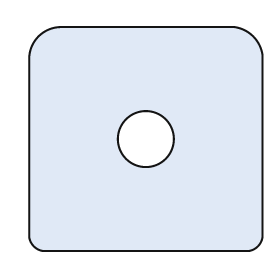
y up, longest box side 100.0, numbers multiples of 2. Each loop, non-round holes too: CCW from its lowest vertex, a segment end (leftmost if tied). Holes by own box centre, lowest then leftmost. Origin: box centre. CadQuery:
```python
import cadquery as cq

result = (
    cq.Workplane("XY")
    .moveTo(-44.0, -48.0)
    .lineTo(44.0, -48.0)
    .threePointArc((48.0, -46.0), (50.0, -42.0))
    .lineTo(50.0, 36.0)
    .threePointArc((46.0, 44.0), (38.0, 48.0))
    .lineTo(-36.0, 48.0)
    .threePointArc((-46.0, 44.0), (-50.0, 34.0))
    .lineTo(-50.0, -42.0)
    .threePointArc((-48.0, -46.0), (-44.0, -48.0))
    .close()
    .moveTo(0.0, 0.0)
    .circle(12.0)
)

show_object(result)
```